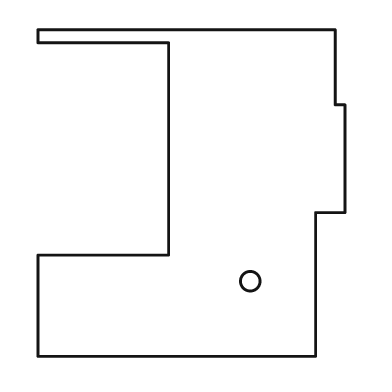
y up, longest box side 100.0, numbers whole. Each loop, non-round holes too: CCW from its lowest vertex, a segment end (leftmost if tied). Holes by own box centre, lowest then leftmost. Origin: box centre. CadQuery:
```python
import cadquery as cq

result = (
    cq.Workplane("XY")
    .moveTo(-47.0, -50.0)
    .lineTo(38.0, -50.0)
    .lineTo(38.0, -6.0)
    .lineTo(47.0, -6.0)
    .lineTo(47.0, 27.0)
    .lineTo(44.0, 27.0)
    .lineTo(44.0, 50.0)
    .lineTo(-47.0, 50.0)
    .lineTo(-47.0, 46.0)
    .lineTo(-7.0, 46.0)
    .lineTo(-7.0, -19.0)
    .lineTo(-47.0, -19.0)
    .close()
    .moveTo(18.0, -27.0)
    .circle(3.0)
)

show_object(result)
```